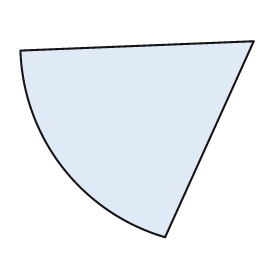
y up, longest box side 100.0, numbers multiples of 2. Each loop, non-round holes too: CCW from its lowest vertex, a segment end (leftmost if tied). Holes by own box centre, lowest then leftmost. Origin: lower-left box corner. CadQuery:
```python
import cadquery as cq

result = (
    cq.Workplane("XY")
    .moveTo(62.0, 0.0)
    .lineTo(100.0, 84.0)
    .lineTo(0.0, 80.0)
    .threePointArc((18.0, 30.0), (62.0, 0.0))
    .close()
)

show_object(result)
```